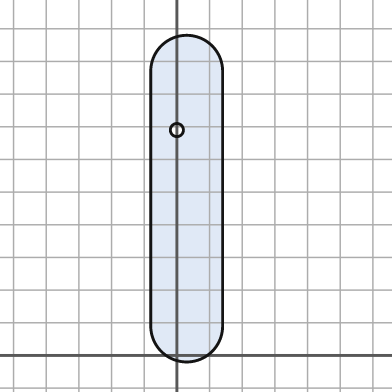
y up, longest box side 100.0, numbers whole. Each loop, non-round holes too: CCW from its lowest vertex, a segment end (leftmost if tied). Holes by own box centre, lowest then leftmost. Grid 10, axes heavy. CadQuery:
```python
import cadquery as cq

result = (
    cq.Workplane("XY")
    .moveTo(-8.0, 9.0)
    .threePointArc((3.0, -2.0), (14.0, 9.0))
    .lineTo(14.0, 87.0)
    .threePointArc((3.0, 98.0), (-8.0, 87.0))
    .close()
    .moveTo(0.0, 69.0)
    .circle(2.0)
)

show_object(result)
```